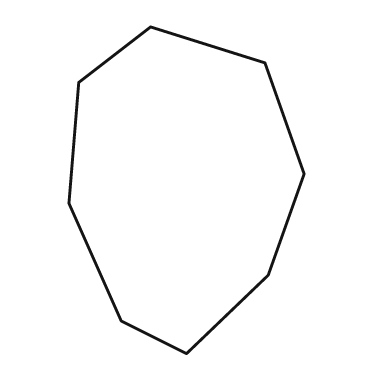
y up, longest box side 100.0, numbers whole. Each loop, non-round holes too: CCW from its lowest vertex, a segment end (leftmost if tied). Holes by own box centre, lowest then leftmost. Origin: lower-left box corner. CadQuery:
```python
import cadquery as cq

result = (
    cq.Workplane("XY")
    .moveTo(36.0, 0.0)
    .lineTo(61.0, 24.0)
    .lineTo(72.0, 55.0)
    .lineTo(60.0, 89.0)
    .lineTo(25.0, 100.0)
    .lineTo(3.0, 83.0)
    .lineTo(0.0, 46.0)
    .lineTo(16.0, 10.0)
    .close()
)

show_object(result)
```